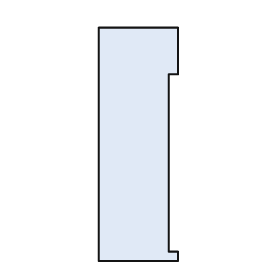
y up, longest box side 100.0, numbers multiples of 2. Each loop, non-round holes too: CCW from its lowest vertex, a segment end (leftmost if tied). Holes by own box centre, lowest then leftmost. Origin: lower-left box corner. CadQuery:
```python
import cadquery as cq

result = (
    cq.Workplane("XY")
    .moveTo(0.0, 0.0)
    .lineTo(34.0, 0.0)
    .lineTo(34.0, 4.0)
    .lineTo(30.0, 4.0)
    .lineTo(30.0, 80.0)
    .lineTo(34.0, 80.0)
    .lineTo(34.0, 100.0)
    .lineTo(0.0, 100.0)
    .close()
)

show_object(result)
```